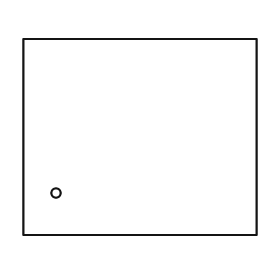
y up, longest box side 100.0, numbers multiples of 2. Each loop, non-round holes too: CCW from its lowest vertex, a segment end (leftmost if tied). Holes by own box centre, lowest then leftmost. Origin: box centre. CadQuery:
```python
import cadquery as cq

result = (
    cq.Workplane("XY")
    .moveTo(-50.0, -42.0)
    .lineTo(50.0, -42.0)
    .lineTo(50.0, 42.0)
    .lineTo(-50.0, 42.0)
    .close()
    .moveTo(-36.0, -24.0)
    .circle(2.0)
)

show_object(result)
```